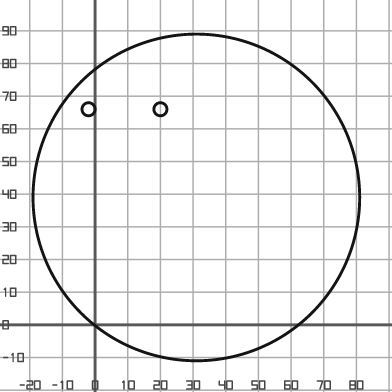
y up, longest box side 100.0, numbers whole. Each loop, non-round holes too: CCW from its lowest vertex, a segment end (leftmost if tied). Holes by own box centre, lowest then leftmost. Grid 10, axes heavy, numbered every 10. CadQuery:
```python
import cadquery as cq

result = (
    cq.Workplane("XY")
    .moveTo(31.0, 39.0)
    .circle(50.0)
    .moveTo(-2.0, 66.0)
    .circle(2.0)
    .moveTo(20.0, 66.0)
    .circle(2.0)
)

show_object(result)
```